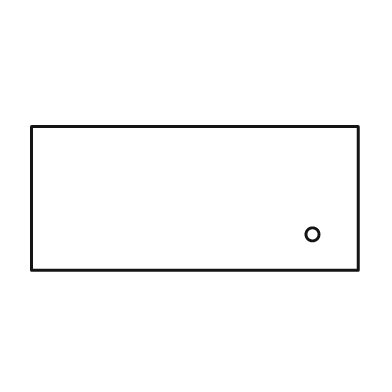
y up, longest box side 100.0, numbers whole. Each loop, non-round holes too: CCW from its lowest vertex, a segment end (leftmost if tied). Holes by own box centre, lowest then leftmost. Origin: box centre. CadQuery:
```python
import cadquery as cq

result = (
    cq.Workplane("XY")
    .moveTo(-50.0, -22.0)
    .lineTo(50.0, -22.0)
    .lineTo(50.0, 22.0)
    .lineTo(-50.0, 22.0)
    .close()
    .moveTo(36.0, -11.0)
    .circle(2.0)
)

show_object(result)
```